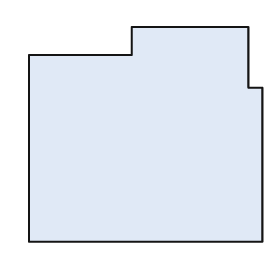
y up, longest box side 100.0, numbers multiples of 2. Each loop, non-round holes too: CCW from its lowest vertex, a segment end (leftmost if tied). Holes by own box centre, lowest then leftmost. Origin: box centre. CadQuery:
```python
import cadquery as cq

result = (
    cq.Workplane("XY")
    .moveTo(-50.0, -46.0)
    .lineTo(50.0, -46.0)
    .lineTo(50.0, 20.0)
    .lineTo(44.0, 20.0)
    .lineTo(44.0, 46.0)
    .lineTo(-6.0, 46.0)
    .lineTo(-6.0, 34.0)
    .lineTo(-50.0, 34.0)
    .close()
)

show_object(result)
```